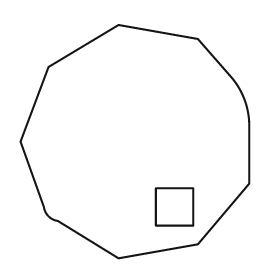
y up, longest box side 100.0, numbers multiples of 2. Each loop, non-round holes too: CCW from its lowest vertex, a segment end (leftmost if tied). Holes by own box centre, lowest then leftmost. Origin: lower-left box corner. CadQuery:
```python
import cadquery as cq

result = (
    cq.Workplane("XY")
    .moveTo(42.0, 0.0)
    .lineTo(76.0, 6.0)
    .lineTo(98.0, 32.0)
    .lineTo(98.0, 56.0)
    .threePointArc((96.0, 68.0), (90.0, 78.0))
    .lineTo(76.0, 94.0)
    .lineTo(42.0, 100.0)
    .lineTo(12.0, 82.0)
    .lineTo(0.0, 50.0)
    .lineTo(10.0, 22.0)
    .threePointArc((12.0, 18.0), (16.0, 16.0))
    .close()
    .moveTo(58.0, 14.0)
    .lineTo(74.0, 14.0)
    .lineTo(74.0, 30.0)
    .lineTo(58.0, 30.0)
    .close()
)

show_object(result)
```